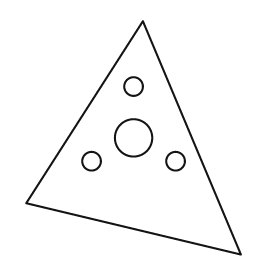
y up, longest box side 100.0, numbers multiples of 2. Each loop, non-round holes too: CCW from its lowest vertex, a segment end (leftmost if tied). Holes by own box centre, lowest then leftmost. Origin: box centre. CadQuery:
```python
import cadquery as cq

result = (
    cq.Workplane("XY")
    .moveTo(46.0, -50.0)
    .lineTo(4.0, 50.0)
    .lineTo(-46.0, -28.0)
    .close()
    .moveTo(-18.0, -10.0)
    .circle(4.0)
    .moveTo(18.0, -10.0)
    .circle(4.0)
    .moveTo(0.0, 0.0)
    .circle(8.0)
    .moveTo(0.0, 22.0)
    .circle(4.0)
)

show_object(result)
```